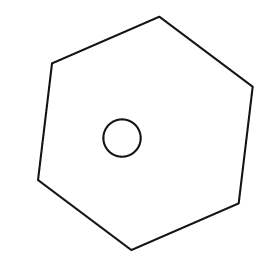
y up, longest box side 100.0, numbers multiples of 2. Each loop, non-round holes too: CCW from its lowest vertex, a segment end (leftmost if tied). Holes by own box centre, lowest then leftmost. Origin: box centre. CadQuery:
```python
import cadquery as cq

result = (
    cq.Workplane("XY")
    .moveTo(-6.0, -50.0)
    .lineTo(40.0, -30.0)
    .lineTo(46.0, 20.0)
    .lineTo(6.0, 50.0)
    .lineTo(-40.0, 30.0)
    .lineTo(-46.0, -20.0)
    .close()
    .moveTo(-10.0, -2.0)
    .circle(8.0)
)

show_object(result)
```